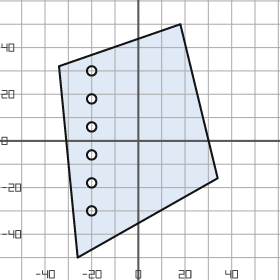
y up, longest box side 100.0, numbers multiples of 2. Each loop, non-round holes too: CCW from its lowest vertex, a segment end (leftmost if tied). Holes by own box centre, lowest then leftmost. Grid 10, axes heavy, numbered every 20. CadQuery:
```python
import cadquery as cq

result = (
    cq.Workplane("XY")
    .moveTo(-26.0, -50.0)
    .lineTo(34.0, -16.0)
    .lineTo(18.0, 50.0)
    .lineTo(-34.0, 32.0)
    .close()
    .moveTo(-20.0, -30.0)
    .circle(2.0)
    .moveTo(-20.0, -18.0)
    .circle(2.0)
    .moveTo(-20.0, -6.0)
    .circle(2.0)
    .moveTo(-20.0, 6.0)
    .circle(2.0)
    .moveTo(-20.0, 18.0)
    .circle(2.0)
    .moveTo(-20.0, 30.0)
    .circle(2.0)
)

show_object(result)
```